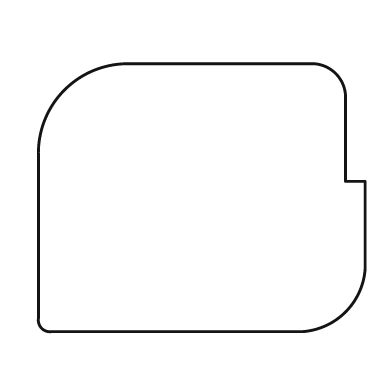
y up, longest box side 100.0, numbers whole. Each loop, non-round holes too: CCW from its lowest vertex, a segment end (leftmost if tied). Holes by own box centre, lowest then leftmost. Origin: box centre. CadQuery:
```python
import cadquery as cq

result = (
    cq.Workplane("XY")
    .moveTo(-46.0, -41.0)
    .lineTo(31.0, -41.0)
    .threePointArc((44.0, -35.0), (50.0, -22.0))
    .lineTo(50.0, 5.0)
    .lineTo(44.0, 5.0)
    .lineTo(44.0, 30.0)
    .threePointArc((41.0, 38.0), (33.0, 41.0))
    .lineTo(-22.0, 41.0)
    .threePointArc((-42.0, 33.0), (-50.0, 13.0))
    .lineTo(-50.0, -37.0)
    .threePointArc((-49.0, -40.0), (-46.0, -41.0))
    .close()
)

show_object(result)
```